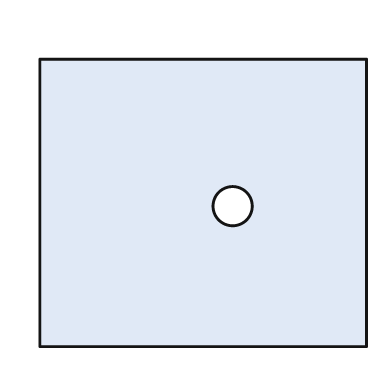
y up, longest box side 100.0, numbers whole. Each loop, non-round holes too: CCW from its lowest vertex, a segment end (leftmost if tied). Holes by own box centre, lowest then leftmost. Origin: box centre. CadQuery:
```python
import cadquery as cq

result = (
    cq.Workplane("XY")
    .moveTo(-50.0, -44.0)
    .lineTo(50.0, -44.0)
    .lineTo(50.0, 44.0)
    .lineTo(-50.0, 44.0)
    .close()
    .moveTo(9.0, -1.0)
    .circle(6.0)
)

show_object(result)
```